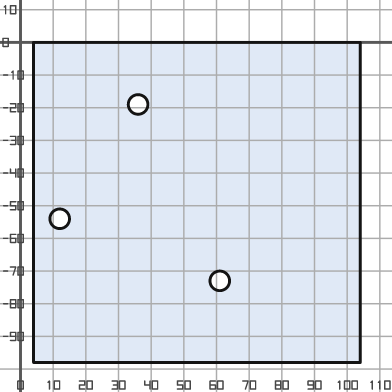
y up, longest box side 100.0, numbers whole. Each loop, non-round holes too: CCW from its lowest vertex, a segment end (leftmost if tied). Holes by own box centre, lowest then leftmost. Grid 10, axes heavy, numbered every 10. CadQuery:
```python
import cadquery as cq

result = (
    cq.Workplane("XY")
    .moveTo(4.0, -98.0)
    .lineTo(104.0, -98.0)
    .lineTo(104.0, 0.0)
    .lineTo(4.0, 0.0)
    .close()
    .moveTo(61.0, -73.0)
    .circle(3.0)
    .moveTo(12.0, -54.0)
    .circle(3.0)
    .moveTo(36.0, -19.0)
    .circle(3.0)
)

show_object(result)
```